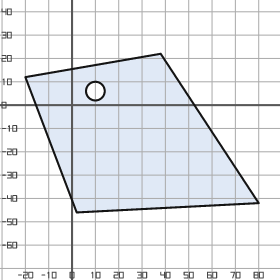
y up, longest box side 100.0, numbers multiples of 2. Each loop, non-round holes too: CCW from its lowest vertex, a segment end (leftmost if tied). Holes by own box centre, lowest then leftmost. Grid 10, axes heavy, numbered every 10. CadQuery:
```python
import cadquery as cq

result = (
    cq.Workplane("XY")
    .moveTo(2.0, -46.0)
    .lineTo(80.0, -42.0)
    .lineTo(38.0, 22.0)
    .lineTo(-20.0, 12.0)
    .close()
    .moveTo(10.0, 6.0)
    .circle(4.0)
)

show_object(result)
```